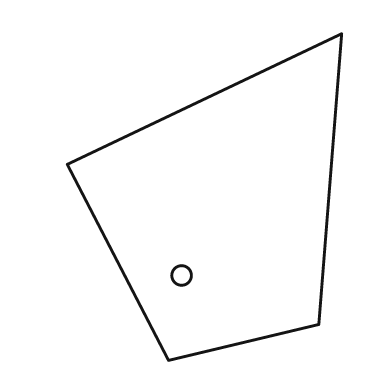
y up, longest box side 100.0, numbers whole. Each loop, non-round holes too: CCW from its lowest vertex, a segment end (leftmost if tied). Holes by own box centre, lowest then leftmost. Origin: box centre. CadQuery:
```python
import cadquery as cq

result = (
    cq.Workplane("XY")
    .moveTo(-11.0, -50.0)
    .lineTo(35.0, -39.0)
    .lineTo(42.0, 50.0)
    .lineTo(-42.0, 10.0)
    .close()
    .moveTo(-7.0, -24.0)
    .circle(3.0)
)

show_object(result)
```